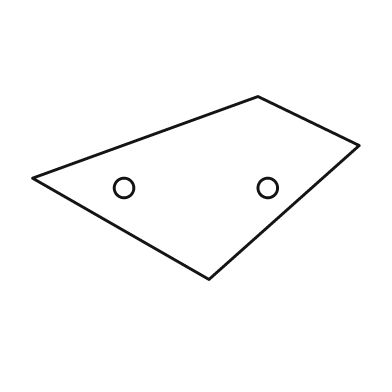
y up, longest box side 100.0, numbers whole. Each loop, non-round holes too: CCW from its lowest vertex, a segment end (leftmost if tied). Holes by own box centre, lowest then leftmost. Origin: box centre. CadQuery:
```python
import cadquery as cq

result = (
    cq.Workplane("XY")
    .moveTo(4.0, -28.0)
    .lineTo(50.0, 13.0)
    .lineTo(19.0, 28.0)
    .lineTo(-50.0, 3.0)
    .close()
    .moveTo(-22.0, 0.0)
    .circle(3.0)
    .moveTo(22.0, 0.0)
    .circle(3.0)
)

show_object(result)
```